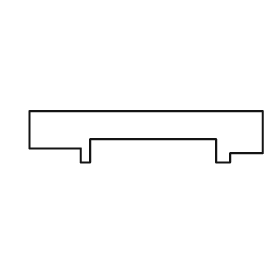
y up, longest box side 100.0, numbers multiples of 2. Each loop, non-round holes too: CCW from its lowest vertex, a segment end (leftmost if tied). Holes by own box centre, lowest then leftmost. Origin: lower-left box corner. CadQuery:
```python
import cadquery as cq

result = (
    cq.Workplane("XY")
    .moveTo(22.0, 0.0)
    .lineTo(26.0, 0.0)
    .lineTo(26.0, 10.0)
    .lineTo(80.0, 10.0)
    .lineTo(80.0, 0.0)
    .lineTo(86.0, 0.0)
    .lineTo(86.0, 4.0)
    .lineTo(100.0, 4.0)
    .lineTo(100.0, 22.0)
    .lineTo(0.0, 22.0)
    .lineTo(0.0, 6.0)
    .lineTo(22.0, 6.0)
    .close()
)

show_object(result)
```